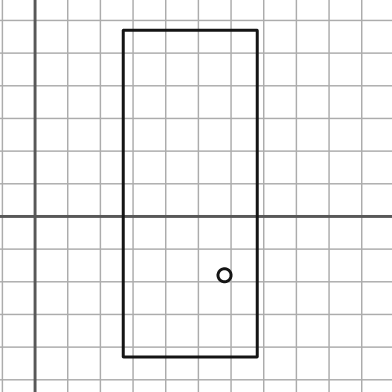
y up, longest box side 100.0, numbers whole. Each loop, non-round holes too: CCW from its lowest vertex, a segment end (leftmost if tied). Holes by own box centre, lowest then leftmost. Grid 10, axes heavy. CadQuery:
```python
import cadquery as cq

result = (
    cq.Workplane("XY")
    .moveTo(27.0, -43.0)
    .lineTo(68.0, -43.0)
    .lineTo(68.0, 57.0)
    .lineTo(27.0, 57.0)
    .close()
    .moveTo(58.0, -18.0)
    .circle(2.0)
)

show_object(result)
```